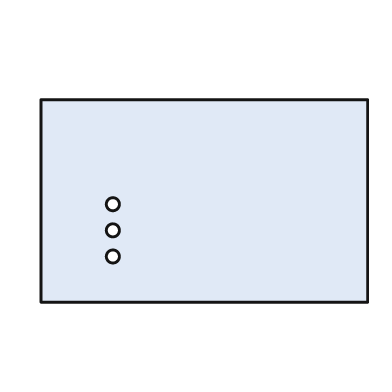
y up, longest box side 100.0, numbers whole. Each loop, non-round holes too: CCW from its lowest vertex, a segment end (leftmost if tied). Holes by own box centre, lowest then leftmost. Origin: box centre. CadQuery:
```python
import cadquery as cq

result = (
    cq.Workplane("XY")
    .moveTo(-50.0, -31.0)
    .lineTo(50.0, -31.0)
    .lineTo(50.0, 31.0)
    .lineTo(-50.0, 31.0)
    .close()
    .moveTo(-28.0, -17.0)
    .circle(2.0)
    .moveTo(-28.0, -9.0)
    .circle(2.0)
    .moveTo(-28.0, -1.0)
    .circle(2.0)
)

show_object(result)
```